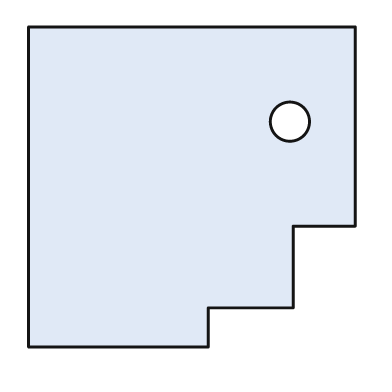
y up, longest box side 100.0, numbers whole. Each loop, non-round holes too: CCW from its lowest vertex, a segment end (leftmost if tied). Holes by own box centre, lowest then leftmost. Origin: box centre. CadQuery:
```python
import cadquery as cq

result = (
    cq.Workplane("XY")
    .moveTo(-50.0, -49.0)
    .lineTo(5.0, -49.0)
    .lineTo(5.0, -37.0)
    .lineTo(31.0, -37.0)
    .lineTo(31.0, -12.0)
    .lineTo(50.0, -12.0)
    .lineTo(50.0, 49.0)
    .lineTo(-50.0, 49.0)
    .close()
    .moveTo(30.0, 20.0)
    .circle(6.0)
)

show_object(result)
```